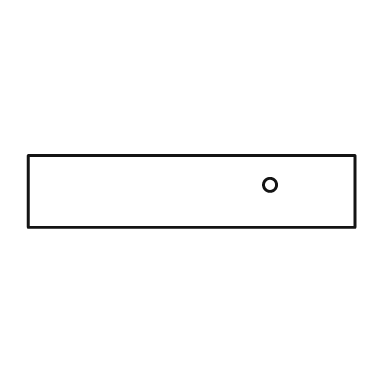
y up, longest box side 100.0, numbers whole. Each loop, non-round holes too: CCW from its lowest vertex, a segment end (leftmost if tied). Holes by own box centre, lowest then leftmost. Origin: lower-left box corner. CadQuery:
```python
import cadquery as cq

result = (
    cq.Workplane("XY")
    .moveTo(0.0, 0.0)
    .lineTo(100.0, 0.0)
    .lineTo(100.0, 22.0)
    .lineTo(0.0, 22.0)
    .close()
    .moveTo(74.0, 13.0)
    .circle(2.0)
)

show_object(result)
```